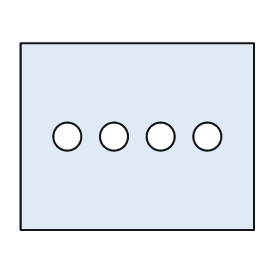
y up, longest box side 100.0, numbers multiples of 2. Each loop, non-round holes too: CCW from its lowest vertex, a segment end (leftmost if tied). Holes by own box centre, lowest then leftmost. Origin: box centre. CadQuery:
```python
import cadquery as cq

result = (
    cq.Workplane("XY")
    .moveTo(-50.0, -40.0)
    .lineTo(50.0, -40.0)
    .lineTo(50.0, 40.0)
    .lineTo(-50.0, 40.0)
    .close()
    .moveTo(-30.0, 0.0)
    .circle(6.0)
    .moveTo(-10.0, 0.0)
    .circle(6.0)
    .moveTo(10.0, 0.0)
    .circle(6.0)
    .moveTo(30.0, 0.0)
    .circle(6.0)
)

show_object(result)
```